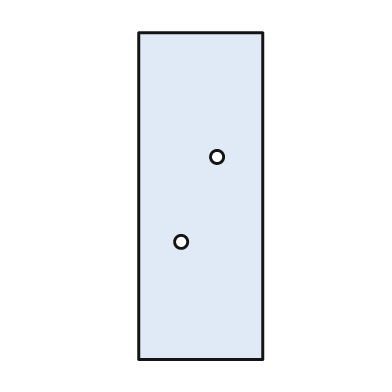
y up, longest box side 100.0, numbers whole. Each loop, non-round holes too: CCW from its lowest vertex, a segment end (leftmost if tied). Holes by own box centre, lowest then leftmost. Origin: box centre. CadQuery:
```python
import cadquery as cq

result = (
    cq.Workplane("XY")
    .moveTo(-19.0, -50.0)
    .lineTo(19.0, -50.0)
    .lineTo(19.0, 50.0)
    .lineTo(-19.0, 50.0)
    .close()
    .moveTo(-6.0, -14.0)
    .circle(2.0)
    .moveTo(5.0, 12.0)
    .circle(2.0)
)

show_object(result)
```